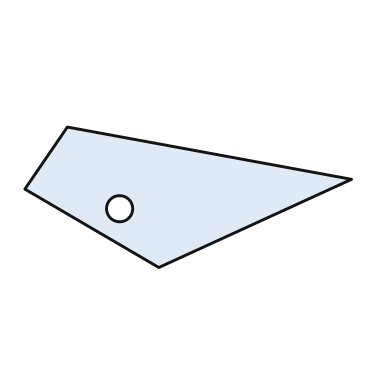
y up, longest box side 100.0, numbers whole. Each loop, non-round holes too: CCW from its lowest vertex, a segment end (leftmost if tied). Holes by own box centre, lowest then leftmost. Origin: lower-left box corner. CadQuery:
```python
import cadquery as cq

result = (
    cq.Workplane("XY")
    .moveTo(41.0, 0.0)
    .lineTo(100.0, 27.0)
    .lineTo(13.0, 43.0)
    .lineTo(0.0, 24.0)
    .close()
    .moveTo(29.0, 18.0)
    .circle(4.0)
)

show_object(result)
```